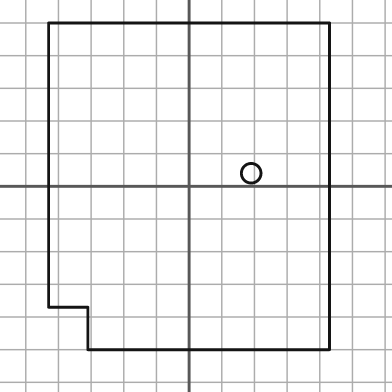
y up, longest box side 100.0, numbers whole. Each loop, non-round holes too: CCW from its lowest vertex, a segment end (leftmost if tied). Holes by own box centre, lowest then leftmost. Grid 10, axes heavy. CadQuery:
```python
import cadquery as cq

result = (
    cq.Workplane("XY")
    .moveTo(-31.0, -50.0)
    .lineTo(43.0, -50.0)
    .lineTo(43.0, 50.0)
    .lineTo(-43.0, 50.0)
    .lineTo(-43.0, -37.0)
    .lineTo(-31.0, -37.0)
    .close()
    .moveTo(19.0, 4.0)
    .circle(3.0)
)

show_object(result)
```